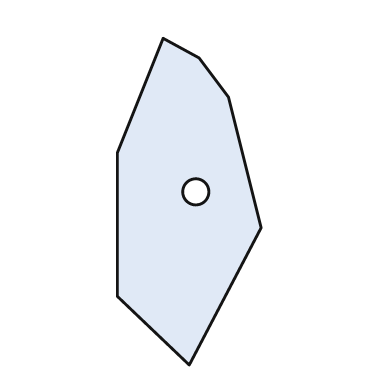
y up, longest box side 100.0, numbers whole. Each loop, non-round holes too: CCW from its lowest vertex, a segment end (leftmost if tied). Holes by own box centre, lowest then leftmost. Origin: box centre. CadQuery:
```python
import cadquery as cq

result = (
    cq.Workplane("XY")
    .moveTo(0.0, -50.0)
    .lineTo(22.0, -8.0)
    .lineTo(12.0, 32.0)
    .lineTo(3.0, 44.0)
    .lineTo(-8.0, 50.0)
    .lineTo(-22.0, 15.0)
    .lineTo(-22.0, -29.0)
    .close()
    .moveTo(2.0, 3.0)
    .circle(4.0)
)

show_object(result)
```